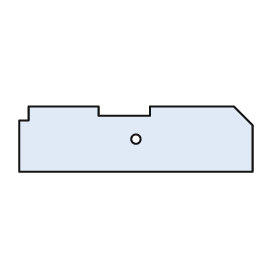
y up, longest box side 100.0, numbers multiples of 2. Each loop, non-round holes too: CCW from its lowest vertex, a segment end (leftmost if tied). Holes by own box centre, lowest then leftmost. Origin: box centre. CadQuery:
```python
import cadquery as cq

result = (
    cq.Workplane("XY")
    .moveTo(-50.0, -14.0)
    .lineTo(50.0, -14.0)
    .lineTo(50.0, 6.0)
    .lineTo(42.0, 14.0)
    .lineTo(6.0, 14.0)
    .lineTo(6.0, 10.0)
    .lineTo(-16.0, 10.0)
    .lineTo(-16.0, 14.0)
    .lineTo(-46.0, 14.0)
    .lineTo(-46.0, 8.0)
    .lineTo(-50.0, 8.0)
    .close()
    .moveTo(0.0, 0.0)
    .circle(2.0)
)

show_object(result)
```